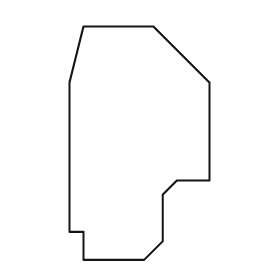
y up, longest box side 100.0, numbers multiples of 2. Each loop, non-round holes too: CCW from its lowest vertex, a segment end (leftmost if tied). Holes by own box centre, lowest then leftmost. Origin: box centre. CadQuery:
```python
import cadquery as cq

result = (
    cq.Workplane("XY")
    .moveTo(-24.0, -50.0)
    .lineTo(2.0, -50.0)
    .lineTo(10.0, -42.0)
    .lineTo(10.0, -22.0)
    .lineTo(16.0, -16.0)
    .lineTo(30.0, -16.0)
    .lineTo(30.0, 26.0)
    .lineTo(6.0, 50.0)
    .lineTo(-24.0, 50.0)
    .lineTo(-30.0, 26.0)
    .lineTo(-30.0, -38.0)
    .lineTo(-24.0, -38.0)
    .close()
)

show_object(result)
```